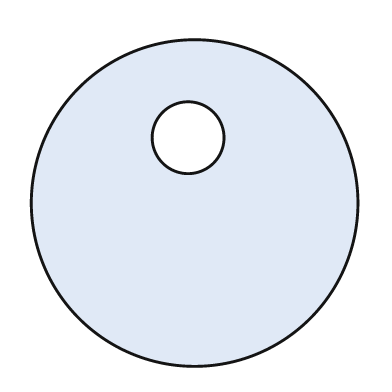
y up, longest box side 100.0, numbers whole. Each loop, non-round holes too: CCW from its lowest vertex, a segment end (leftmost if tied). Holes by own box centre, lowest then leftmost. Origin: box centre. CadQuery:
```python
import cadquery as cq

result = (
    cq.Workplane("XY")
    .moveTo(0.0, 0.0)
    .circle(50.0)
    .moveTo(-2.0, 20.0)
    .circle(11.0)
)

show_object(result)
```